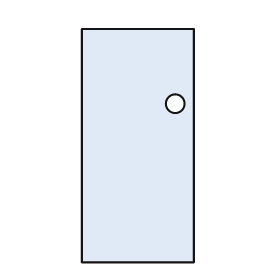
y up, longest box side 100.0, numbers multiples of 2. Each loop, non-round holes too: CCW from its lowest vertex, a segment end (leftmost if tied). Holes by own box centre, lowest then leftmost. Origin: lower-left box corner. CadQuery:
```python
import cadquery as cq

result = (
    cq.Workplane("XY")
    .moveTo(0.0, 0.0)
    .lineTo(48.0, 0.0)
    .lineTo(48.0, 100.0)
    .lineTo(0.0, 100.0)
    .close()
    .moveTo(40.0, 68.0)
    .circle(4.0)
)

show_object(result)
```